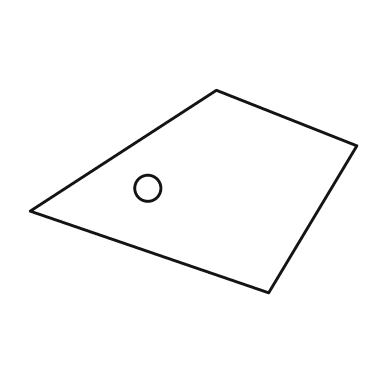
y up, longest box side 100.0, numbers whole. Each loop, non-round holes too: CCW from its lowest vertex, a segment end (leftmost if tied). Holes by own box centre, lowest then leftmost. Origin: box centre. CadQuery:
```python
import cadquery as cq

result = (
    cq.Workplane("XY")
    .moveTo(23.0, -31.0)
    .lineTo(50.0, 14.0)
    .lineTo(7.0, 31.0)
    .lineTo(-50.0, -6.0)
    .close()
    .moveTo(-14.0, 1.0)
    .circle(4.0)
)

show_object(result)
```